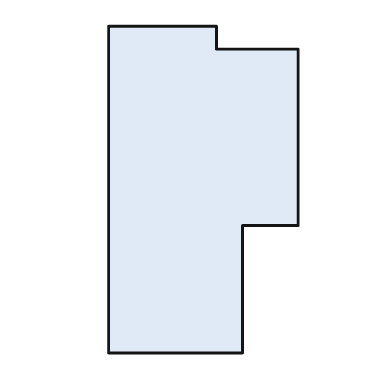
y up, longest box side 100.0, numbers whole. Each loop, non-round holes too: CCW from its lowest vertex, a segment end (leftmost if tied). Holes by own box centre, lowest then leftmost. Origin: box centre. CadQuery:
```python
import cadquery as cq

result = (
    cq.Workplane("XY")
    .moveTo(-29.0, -50.0)
    .lineTo(12.0, -50.0)
    .lineTo(12.0, -11.0)
    .lineTo(29.0, -11.0)
    .lineTo(29.0, 43.0)
    .lineTo(4.0, 43.0)
    .lineTo(4.0, 50.0)
    .lineTo(-29.0, 50.0)
    .close()
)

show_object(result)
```